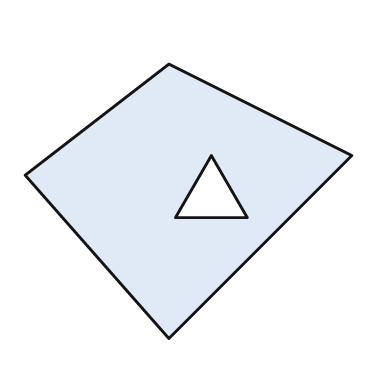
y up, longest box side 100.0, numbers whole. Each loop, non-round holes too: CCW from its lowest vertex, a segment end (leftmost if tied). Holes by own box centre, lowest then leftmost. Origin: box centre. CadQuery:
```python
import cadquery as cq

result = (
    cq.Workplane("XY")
    .moveTo(-6.0, -42.0)
    .lineTo(50.0, 14.0)
    .lineTo(-6.0, 42.0)
    .lineTo(-50.0, 8.0)
    .close()
    .moveTo(-4.0, -5.0)
    .lineTo(18.0, -5.0)
    .lineTo(7.0, 14.0)
    .close()
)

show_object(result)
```